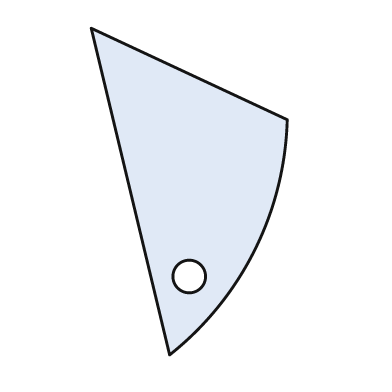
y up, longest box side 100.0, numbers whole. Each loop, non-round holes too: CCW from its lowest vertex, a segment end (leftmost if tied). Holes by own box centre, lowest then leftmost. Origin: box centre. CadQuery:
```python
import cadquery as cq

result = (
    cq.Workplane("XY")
    .moveTo(-6.0, -50.0)
    .threePointArc((20.0, -18.0), (30.0, 22.0))
    .lineTo(-30.0, 50.0)
    .close()
    .moveTo(0.0, -26.0)
    .circle(5.0)
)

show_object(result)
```